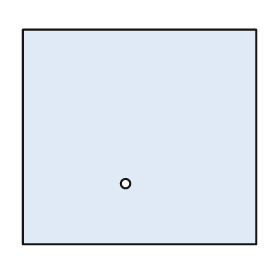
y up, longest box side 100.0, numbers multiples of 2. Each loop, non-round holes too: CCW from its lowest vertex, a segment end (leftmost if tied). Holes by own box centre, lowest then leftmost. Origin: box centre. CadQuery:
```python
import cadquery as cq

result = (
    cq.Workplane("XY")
    .moveTo(-50.0, -46.0)
    .lineTo(50.0, -46.0)
    .lineTo(50.0, 46.0)
    .lineTo(-50.0, 46.0)
    .close()
    .moveTo(-6.0, -20.0)
    .circle(2.0)
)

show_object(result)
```